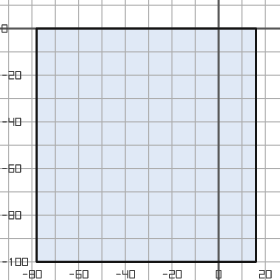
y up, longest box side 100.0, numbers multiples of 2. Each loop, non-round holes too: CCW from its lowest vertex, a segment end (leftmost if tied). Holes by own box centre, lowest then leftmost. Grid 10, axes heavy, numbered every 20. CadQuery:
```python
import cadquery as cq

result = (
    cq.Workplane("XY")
    .moveTo(-78.0, -100.0)
    .lineTo(16.0, -100.0)
    .lineTo(16.0, 0.0)
    .lineTo(-78.0, 0.0)
    .close()
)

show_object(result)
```